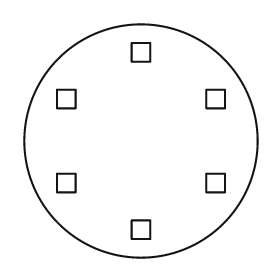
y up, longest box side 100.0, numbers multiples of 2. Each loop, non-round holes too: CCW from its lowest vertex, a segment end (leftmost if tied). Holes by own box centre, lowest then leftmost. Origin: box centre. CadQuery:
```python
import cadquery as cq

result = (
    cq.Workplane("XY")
    .moveTo(0.0, 0.0)
    .circle(50.0)
    .moveTo(-4.0, -42.0)
    .lineTo(4.0, -42.0)
    .lineTo(4.0, -34.0)
    .lineTo(-4.0, -34.0)
    .close()
    .moveTo(-36.0, -22.0)
    .lineTo(-28.0, -22.0)
    .lineTo(-28.0, -14.0)
    .lineTo(-36.0, -14.0)
    .close()
    .moveTo(28.0, -22.0)
    .lineTo(36.0, -22.0)
    .lineTo(36.0, -14.0)
    .lineTo(28.0, -14.0)
    .close()
    .moveTo(-36.0, 14.0)
    .lineTo(-28.0, 14.0)
    .lineTo(-28.0, 22.0)
    .lineTo(-36.0, 22.0)
    .close()
    .moveTo(28.0, 14.0)
    .lineTo(36.0, 14.0)
    .lineTo(36.0, 22.0)
    .lineTo(28.0, 22.0)
    .close()
    .moveTo(-4.0, 34.0)
    .lineTo(4.0, 34.0)
    .lineTo(4.0, 42.0)
    .lineTo(-4.0, 42.0)
    .close()
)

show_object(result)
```